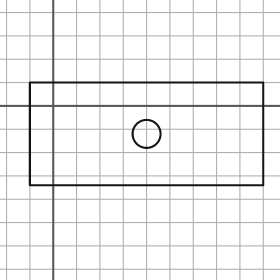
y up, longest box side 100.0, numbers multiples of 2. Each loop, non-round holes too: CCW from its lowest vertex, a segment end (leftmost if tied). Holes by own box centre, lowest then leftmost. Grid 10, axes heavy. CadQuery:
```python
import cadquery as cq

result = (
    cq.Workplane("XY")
    .moveTo(-10.0, -34.0)
    .lineTo(90.0, -34.0)
    .lineTo(90.0, 10.0)
    .lineTo(-10.0, 10.0)
    .close()
    .moveTo(40.0, -12.0)
    .circle(6.0)
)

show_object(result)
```